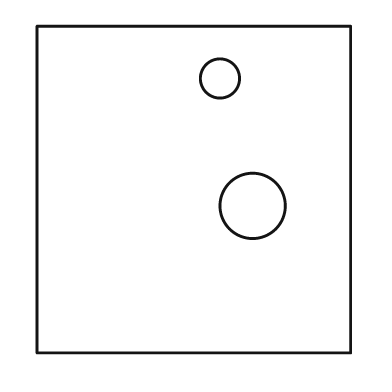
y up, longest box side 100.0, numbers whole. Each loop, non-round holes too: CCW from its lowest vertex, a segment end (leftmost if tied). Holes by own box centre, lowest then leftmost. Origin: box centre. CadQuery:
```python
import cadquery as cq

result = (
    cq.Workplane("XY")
    .moveTo(-48.0, -50.0)
    .lineTo(48.0, -50.0)
    .lineTo(48.0, 50.0)
    .lineTo(-48.0, 50.0)
    .close()
    .moveTo(18.0, -5.0)
    .circle(10.0)
    .moveTo(8.0, 34.0)
    .circle(6.0)
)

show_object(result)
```